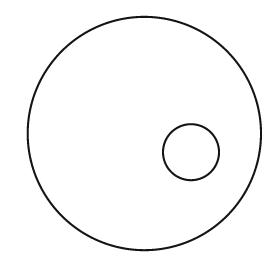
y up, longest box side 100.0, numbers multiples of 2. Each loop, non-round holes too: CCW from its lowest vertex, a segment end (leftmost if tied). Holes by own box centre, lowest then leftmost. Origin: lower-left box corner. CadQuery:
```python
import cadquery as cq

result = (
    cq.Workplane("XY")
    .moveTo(50.0, 50.0)
    .circle(50.0)
    .moveTo(70.0, 42.0)
    .circle(12.0)
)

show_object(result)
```